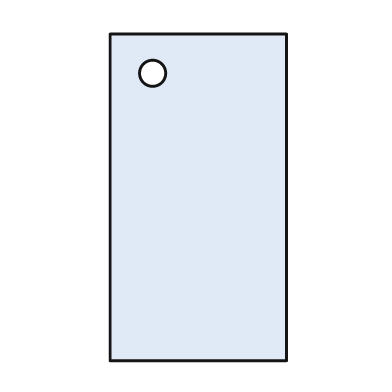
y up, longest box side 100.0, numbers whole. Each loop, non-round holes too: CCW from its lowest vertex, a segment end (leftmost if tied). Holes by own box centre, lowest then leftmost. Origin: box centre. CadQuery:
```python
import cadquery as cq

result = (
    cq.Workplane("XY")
    .moveTo(-27.0, -50.0)
    .lineTo(27.0, -50.0)
    .lineTo(27.0, 50.0)
    .lineTo(-27.0, 50.0)
    .close()
    .moveTo(-14.0, 38.0)
    .circle(4.0)
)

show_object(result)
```